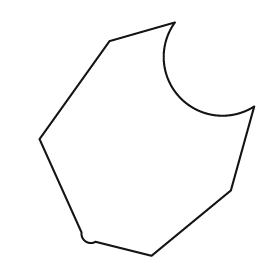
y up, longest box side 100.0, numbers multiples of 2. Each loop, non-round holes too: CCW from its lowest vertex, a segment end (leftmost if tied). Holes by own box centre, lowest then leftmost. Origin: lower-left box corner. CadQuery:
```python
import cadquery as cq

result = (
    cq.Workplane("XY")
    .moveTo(48.0, 0.0)
    .lineTo(82.0, 28.0)
    .lineTo(92.0, 64.0)
    .threePointArc((60.0, 68.0), (58.0, 100.0))
    .lineTo(30.0, 92.0)
    .lineTo(0.0, 50.0)
    .lineTo(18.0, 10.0)
    .threePointArc((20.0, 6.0), (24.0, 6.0))
    .close()
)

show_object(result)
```